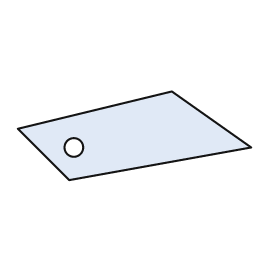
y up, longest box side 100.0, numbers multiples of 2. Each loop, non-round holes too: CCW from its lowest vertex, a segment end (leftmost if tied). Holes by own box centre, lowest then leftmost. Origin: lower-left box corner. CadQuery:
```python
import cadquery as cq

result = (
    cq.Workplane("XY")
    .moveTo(22.0, 0.0)
    .lineTo(100.0, 14.0)
    .lineTo(66.0, 38.0)
    .lineTo(0.0, 22.0)
    .close()
    .moveTo(24.0, 14.0)
    .circle(4.0)
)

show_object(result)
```